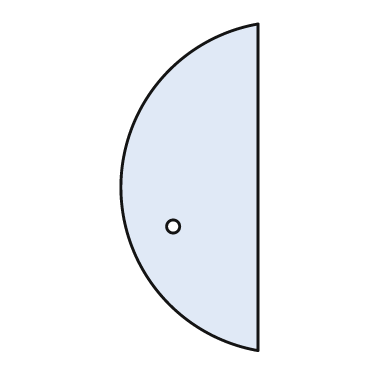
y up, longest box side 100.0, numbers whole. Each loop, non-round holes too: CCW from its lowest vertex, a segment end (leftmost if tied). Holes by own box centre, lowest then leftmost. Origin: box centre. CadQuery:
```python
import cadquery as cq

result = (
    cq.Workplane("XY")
    .moveTo(21.0, -50.0)
    .lineTo(21.0, 50.0)
    .threePointArc((-21.0, 0.0), (21.0, -50.0))
    .close()
    .moveTo(-5.0, -12.0)
    .circle(2.0)
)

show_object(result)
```